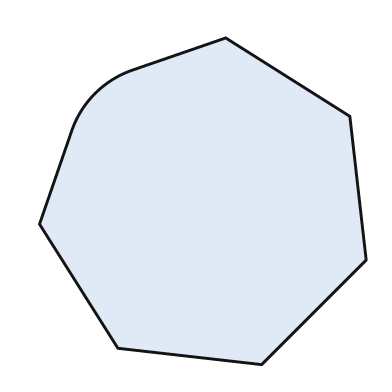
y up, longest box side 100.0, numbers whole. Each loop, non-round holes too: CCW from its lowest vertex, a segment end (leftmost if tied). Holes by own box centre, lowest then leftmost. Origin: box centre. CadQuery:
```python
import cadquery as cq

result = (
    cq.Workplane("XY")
    .moveTo(18.0, -50.0)
    .lineTo(50.0, -18.0)
    .lineTo(45.0, 26.0)
    .lineTo(7.0, 50.0)
    .lineTo(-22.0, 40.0)
    .threePointArc((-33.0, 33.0), (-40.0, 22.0))
    .lineTo(-50.0, -7.0)
    .lineTo(-26.0, -45.0)
    .close()
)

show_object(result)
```